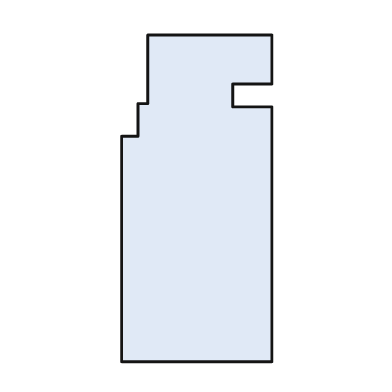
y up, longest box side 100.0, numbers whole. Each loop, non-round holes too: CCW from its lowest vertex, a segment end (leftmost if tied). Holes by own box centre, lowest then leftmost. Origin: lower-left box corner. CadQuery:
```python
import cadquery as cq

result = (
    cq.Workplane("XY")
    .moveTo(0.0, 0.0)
    .lineTo(46.0, 0.0)
    .lineTo(46.0, 78.0)
    .lineTo(34.0, 78.0)
    .lineTo(34.0, 85.0)
    .lineTo(46.0, 85.0)
    .lineTo(46.0, 100.0)
    .lineTo(8.0, 100.0)
    .lineTo(8.0, 79.0)
    .lineTo(5.0, 79.0)
    .lineTo(5.0, 69.0)
    .lineTo(0.0, 69.0)
    .close()
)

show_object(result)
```